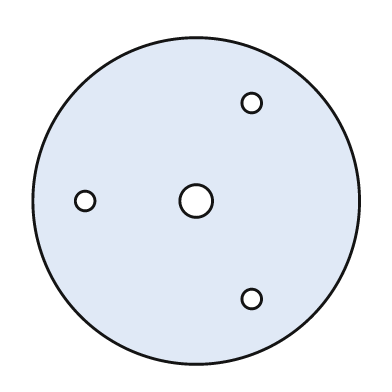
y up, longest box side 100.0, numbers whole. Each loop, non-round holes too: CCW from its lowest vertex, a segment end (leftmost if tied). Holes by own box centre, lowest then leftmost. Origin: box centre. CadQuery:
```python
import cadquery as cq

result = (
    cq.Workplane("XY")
    .moveTo(0.0, 0.0)
    .circle(50.0)
    .moveTo(17.0, -30.0)
    .circle(3.0)
    .moveTo(-34.0, 0.0)
    .circle(3.0)
    .moveTo(0.0, 0.0)
    .circle(5.0)
    .moveTo(17.0, 30.0)
    .circle(3.0)
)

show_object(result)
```